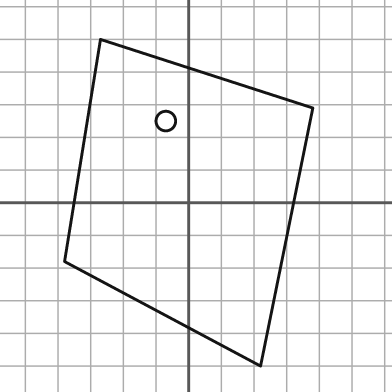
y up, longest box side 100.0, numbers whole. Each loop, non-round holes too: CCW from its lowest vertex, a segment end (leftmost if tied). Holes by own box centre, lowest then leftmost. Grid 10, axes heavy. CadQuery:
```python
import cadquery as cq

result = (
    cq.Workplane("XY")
    .moveTo(22.0, -50.0)
    .lineTo(38.0, 29.0)
    .lineTo(-27.0, 50.0)
    .lineTo(-38.0, -18.0)
    .close()
    .moveTo(-7.0, 25.0)
    .circle(3.0)
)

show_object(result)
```